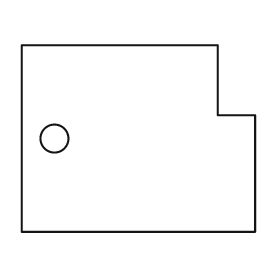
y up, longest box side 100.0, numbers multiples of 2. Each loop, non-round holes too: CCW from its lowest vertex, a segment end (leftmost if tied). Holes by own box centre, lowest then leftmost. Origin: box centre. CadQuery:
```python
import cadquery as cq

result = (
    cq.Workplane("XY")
    .moveTo(-50.0, -40.0)
    .lineTo(50.0, -40.0)
    .lineTo(50.0, 10.0)
    .lineTo(34.0, 10.0)
    .lineTo(34.0, 40.0)
    .lineTo(-50.0, 40.0)
    .close()
    .moveTo(-36.0, 0.0)
    .circle(6.0)
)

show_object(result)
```